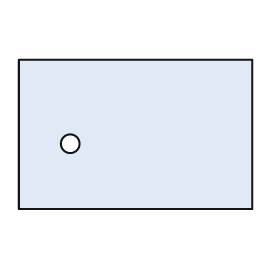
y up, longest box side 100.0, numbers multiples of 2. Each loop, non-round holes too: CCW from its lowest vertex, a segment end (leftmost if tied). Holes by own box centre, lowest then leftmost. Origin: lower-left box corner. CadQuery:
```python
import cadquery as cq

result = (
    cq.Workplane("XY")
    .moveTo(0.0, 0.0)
    .lineTo(100.0, 0.0)
    .lineTo(100.0, 64.0)
    .lineTo(0.0, 64.0)
    .close()
    .moveTo(22.0, 28.0)
    .circle(4.0)
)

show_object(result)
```